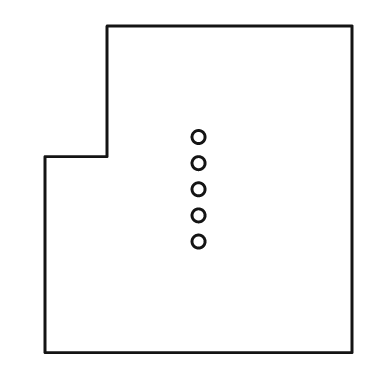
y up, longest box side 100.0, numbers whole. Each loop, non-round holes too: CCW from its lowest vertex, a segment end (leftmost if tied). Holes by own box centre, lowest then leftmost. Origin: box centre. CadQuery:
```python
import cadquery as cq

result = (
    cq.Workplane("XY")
    .moveTo(-47.0, -50.0)
    .lineTo(47.0, -50.0)
    .lineTo(47.0, 50.0)
    .lineTo(-28.0, 50.0)
    .lineTo(-28.0, 10.0)
    .lineTo(-47.0, 10.0)
    .close()
    .moveTo(0.0, -16.0)
    .circle(2.0)
    .moveTo(0.0, -8.0)
    .circle(2.0)
    .moveTo(0.0, 0.0)
    .circle(2.0)
    .moveTo(0.0, 8.0)
    .circle(2.0)
    .moveTo(0.0, 16.0)
    .circle(2.0)
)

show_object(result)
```